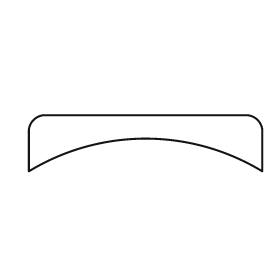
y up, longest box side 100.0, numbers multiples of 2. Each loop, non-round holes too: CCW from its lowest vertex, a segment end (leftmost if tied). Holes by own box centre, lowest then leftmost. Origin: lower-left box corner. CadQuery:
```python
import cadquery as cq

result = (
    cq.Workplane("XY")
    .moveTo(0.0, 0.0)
    .threePointArc((50.0, 14.0), (100.0, 0.0))
    .lineTo(100.0, 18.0)
    .threePointArc((98.0, 22.0), (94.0, 24.0))
    .lineTo(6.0, 24.0)
    .threePointArc((2.0, 22.0), (0.0, 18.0))
    .close()
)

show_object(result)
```